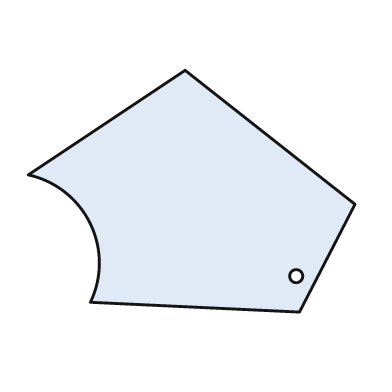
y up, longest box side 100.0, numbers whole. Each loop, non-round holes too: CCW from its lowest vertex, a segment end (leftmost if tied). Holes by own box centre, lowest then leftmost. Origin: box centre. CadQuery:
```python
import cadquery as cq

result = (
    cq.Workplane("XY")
    .moveTo(33.0, -37.0)
    .lineTo(50.0, -4.0)
    .lineTo(-2.0, 37.0)
    .lineTo(-50.0, 5.0)
    .threePointArc((-31.0, -10.0), (-31.0, -34.0))
    .close()
    .moveTo(32.0, -26.0)
    .circle(2.0)
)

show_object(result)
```